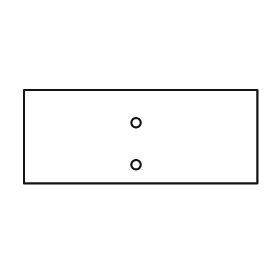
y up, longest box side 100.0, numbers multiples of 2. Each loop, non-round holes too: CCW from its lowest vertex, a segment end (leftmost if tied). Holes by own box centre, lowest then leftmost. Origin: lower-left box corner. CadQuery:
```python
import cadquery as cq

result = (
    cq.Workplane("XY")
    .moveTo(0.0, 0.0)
    .lineTo(100.0, 0.0)
    .lineTo(100.0, 40.0)
    .lineTo(0.0, 40.0)
    .close()
    .moveTo(48.0, 8.0)
    .circle(2.0)
    .moveTo(48.0, 26.0)
    .circle(2.0)
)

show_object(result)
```